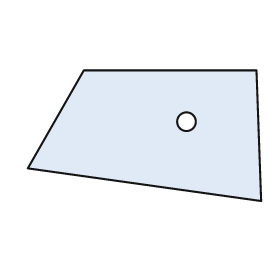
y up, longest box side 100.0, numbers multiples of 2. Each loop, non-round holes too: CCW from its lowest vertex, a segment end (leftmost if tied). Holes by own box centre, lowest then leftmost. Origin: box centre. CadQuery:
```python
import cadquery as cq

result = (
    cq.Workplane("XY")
    .moveTo(50.0, -28.0)
    .lineTo(48.0, 28.0)
    .lineTo(-26.0, 28.0)
    .lineTo(-50.0, -14.0)
    .close()
    .moveTo(18.0, 6.0)
    .circle(4.0)
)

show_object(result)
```